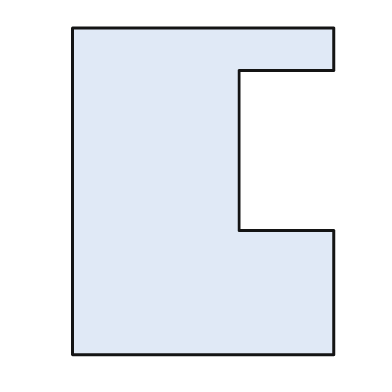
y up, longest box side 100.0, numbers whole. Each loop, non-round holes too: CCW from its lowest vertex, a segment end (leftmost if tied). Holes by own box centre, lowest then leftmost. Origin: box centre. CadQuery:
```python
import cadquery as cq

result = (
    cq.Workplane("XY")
    .moveTo(-40.0, -50.0)
    .lineTo(40.0, -50.0)
    .lineTo(40.0, -12.0)
    .lineTo(11.0, -12.0)
    .lineTo(11.0, 37.0)
    .lineTo(40.0, 37.0)
    .lineTo(40.0, 50.0)
    .lineTo(-40.0, 50.0)
    .close()
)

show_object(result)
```